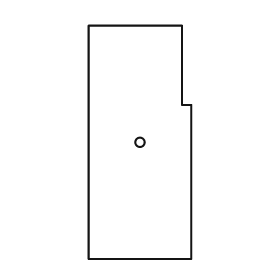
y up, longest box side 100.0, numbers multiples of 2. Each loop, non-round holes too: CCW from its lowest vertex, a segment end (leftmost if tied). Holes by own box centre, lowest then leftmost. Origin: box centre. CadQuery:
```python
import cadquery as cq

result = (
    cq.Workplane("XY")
    .moveTo(-22.0, -50.0)
    .lineTo(22.0, -50.0)
    .lineTo(22.0, 16.0)
    .lineTo(18.0, 16.0)
    .lineTo(18.0, 50.0)
    .lineTo(-22.0, 50.0)
    .close()
    .moveTo(0.0, 0.0)
    .circle(2.0)
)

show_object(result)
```